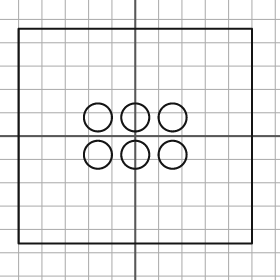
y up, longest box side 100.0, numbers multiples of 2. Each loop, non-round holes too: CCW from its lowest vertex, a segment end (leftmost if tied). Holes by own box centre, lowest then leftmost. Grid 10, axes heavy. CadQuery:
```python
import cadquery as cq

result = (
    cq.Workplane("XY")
    .moveTo(-50.0, -46.0)
    .lineTo(50.0, -46.0)
    .lineTo(50.0, 46.0)
    .lineTo(-50.0, 46.0)
    .close()
    .moveTo(-16.0, -8.0)
    .circle(6.0)
    .moveTo(0.0, -8.0)
    .circle(6.0)
    .moveTo(16.0, -8.0)
    .circle(6.0)
    .moveTo(-16.0, 8.0)
    .circle(6.0)
    .moveTo(0.0, 8.0)
    .circle(6.0)
    .moveTo(16.0, 8.0)
    .circle(6.0)
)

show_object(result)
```